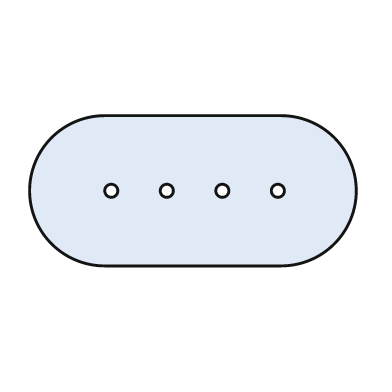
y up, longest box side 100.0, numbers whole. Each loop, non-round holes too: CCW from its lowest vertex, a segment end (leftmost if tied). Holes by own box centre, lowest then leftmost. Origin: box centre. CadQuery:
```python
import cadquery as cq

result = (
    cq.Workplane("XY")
    .moveTo(-27.0, -23.0)
    .lineTo(27.0, -23.0)
    .threePointArc((50.0, 0.0), (27.0, 23.0))
    .lineTo(-27.0, 23.0)
    .threePointArc((-50.0, 0.0), (-27.0, -23.0))
    .close()
    .moveTo(-25.0, 0.0)
    .circle(2.0)
    .moveTo(-8.0, 0.0)
    .circle(2.0)
    .moveTo(9.0, 0.0)
    .circle(2.0)
    .moveTo(26.0, 0.0)
    .circle(2.0)
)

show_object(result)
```